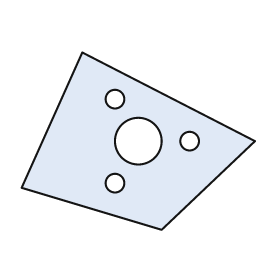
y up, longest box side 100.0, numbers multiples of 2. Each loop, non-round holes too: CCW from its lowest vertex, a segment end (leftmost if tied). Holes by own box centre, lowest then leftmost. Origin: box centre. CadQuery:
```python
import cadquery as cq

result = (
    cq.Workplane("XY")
    .moveTo(10.0, -38.0)
    .lineTo(50.0, 0.0)
    .lineTo(-24.0, 38.0)
    .lineTo(-50.0, -20.0)
    .close()
    .moveTo(-10.0, -18.0)
    .circle(4.0)
    .moveTo(0.0, 0.0)
    .circle(10.0)
    .moveTo(22.0, 0.0)
    .circle(4.0)
    .moveTo(-10.0, 18.0)
    .circle(4.0)
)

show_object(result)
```